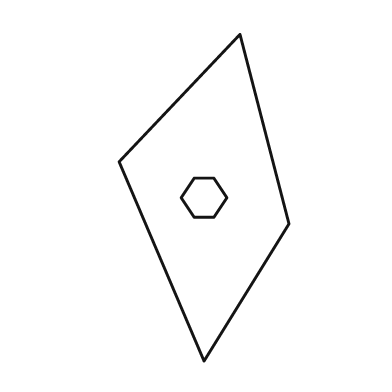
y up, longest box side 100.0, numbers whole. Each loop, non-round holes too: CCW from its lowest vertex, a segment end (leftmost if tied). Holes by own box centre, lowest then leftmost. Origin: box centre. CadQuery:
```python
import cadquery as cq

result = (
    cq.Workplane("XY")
    .moveTo(0.0, -50.0)
    .lineTo(26.0, -8.0)
    .lineTo(11.0, 50.0)
    .lineTo(-26.0, 11.0)
    .close()
    .moveTo(-3.0, -6.0)
    .lineTo(3.0, -6.0)
    .lineTo(7.0, 0.0)
    .lineTo(3.0, 6.0)
    .lineTo(-3.0, 6.0)
    .lineTo(-7.0, 0.0)
    .close()
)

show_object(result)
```